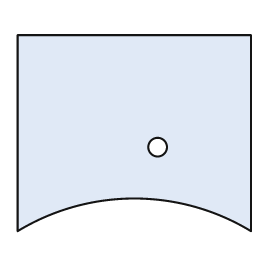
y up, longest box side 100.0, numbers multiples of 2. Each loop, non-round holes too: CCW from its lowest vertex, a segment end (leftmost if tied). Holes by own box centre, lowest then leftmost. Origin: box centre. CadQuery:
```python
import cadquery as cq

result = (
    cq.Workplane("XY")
    .moveTo(-50.0, -42.0)
    .threePointArc((0.0, -28.0), (50.0, -42.0))
    .lineTo(50.0, 42.0)
    .lineTo(-50.0, 42.0)
    .close()
    .moveTo(10.0, -6.0)
    .circle(4.0)
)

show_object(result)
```